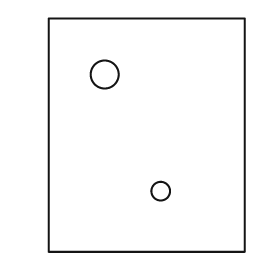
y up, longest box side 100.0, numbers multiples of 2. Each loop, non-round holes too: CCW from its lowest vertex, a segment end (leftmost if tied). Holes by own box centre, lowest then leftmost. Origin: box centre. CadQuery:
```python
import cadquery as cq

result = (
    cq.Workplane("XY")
    .moveTo(-42.0, -50.0)
    .lineTo(42.0, -50.0)
    .lineTo(42.0, 50.0)
    .lineTo(-42.0, 50.0)
    .close()
    .moveTo(6.0, -24.0)
    .circle(4.0)
    .moveTo(-18.0, 26.0)
    .circle(6.0)
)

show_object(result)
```